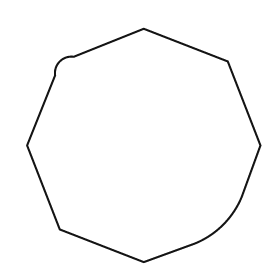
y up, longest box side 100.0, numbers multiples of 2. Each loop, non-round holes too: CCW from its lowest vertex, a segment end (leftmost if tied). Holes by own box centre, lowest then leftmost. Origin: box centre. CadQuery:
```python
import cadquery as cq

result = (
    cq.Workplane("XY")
    .moveTo(0.0, -50.0)
    .lineTo(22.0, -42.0)
    .threePointArc((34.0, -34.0), (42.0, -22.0))
    .lineTo(50.0, 0.0)
    .lineTo(36.0, 36.0)
    .lineTo(0.0, 50.0)
    .lineTo(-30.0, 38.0)
    .threePointArc((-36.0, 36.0), (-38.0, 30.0))
    .lineTo(-50.0, 0.0)
    .lineTo(-36.0, -36.0)
    .close()
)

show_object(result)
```